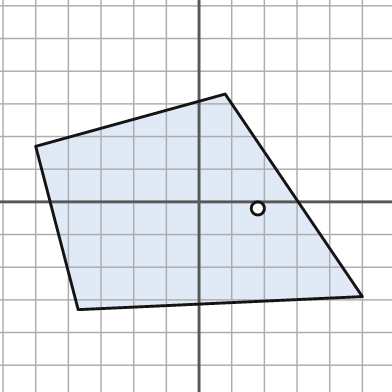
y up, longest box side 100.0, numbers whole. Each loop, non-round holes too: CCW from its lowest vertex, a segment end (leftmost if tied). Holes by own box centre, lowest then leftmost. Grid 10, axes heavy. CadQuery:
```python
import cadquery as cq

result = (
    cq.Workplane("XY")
    .moveTo(-37.0, -33.0)
    .lineTo(50.0, -29.0)
    .lineTo(8.0, 33.0)
    .lineTo(-50.0, 17.0)
    .close()
    .moveTo(18.0, -2.0)
    .circle(2.0)
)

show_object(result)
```